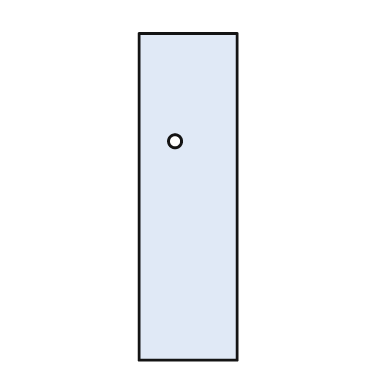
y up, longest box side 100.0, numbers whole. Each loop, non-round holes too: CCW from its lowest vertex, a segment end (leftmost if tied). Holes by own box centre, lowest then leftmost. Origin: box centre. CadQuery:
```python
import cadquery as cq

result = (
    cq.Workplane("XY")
    .moveTo(-15.0, -50.0)
    .lineTo(15.0, -50.0)
    .lineTo(15.0, 50.0)
    .lineTo(-15.0, 50.0)
    .close()
    .moveTo(-4.0, 17.0)
    .circle(2.0)
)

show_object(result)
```